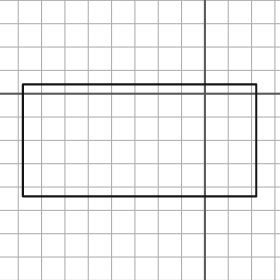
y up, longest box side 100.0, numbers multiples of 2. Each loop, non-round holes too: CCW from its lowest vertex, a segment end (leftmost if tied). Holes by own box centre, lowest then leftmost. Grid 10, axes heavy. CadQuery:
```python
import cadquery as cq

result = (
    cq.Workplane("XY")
    .moveTo(-78.0, -44.0)
    .lineTo(22.0, -44.0)
    .lineTo(22.0, 4.0)
    .lineTo(-78.0, 4.0)
    .close()
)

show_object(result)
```